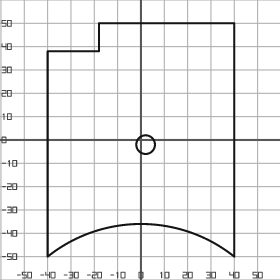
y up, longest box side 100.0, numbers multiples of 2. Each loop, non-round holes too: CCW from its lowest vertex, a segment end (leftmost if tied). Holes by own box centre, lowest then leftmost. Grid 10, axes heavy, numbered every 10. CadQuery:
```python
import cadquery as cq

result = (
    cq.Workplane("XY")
    .moveTo(-40.0, -50.0)
    .threePointArc((0.0, -36.0), (40.0, -50.0))
    .lineTo(40.0, 50.0)
    .lineTo(-18.0, 50.0)
    .lineTo(-18.0, 38.0)
    .lineTo(-40.0, 38.0)
    .close()
    .moveTo(2.0, -2.0)
    .circle(4.0)
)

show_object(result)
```